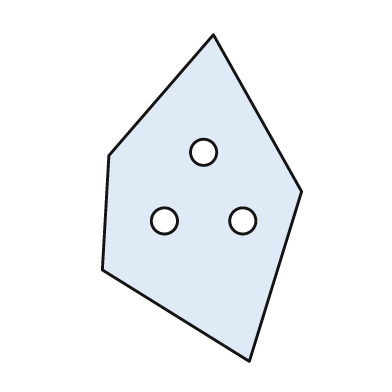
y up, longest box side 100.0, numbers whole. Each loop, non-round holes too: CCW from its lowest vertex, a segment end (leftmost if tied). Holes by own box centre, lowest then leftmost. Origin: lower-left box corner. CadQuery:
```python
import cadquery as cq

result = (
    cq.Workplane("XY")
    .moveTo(45.0, 0.0)
    .lineTo(61.0, 52.0)
    .lineTo(34.0, 100.0)
    .lineTo(2.0, 63.0)
    .lineTo(0.0, 28.0)
    .close()
    .moveTo(19.0, 43.0)
    .circle(4.0)
    .moveTo(43.0, 43.0)
    .circle(4.0)
    .moveTo(31.0, 64.0)
    .circle(4.0)
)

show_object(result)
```